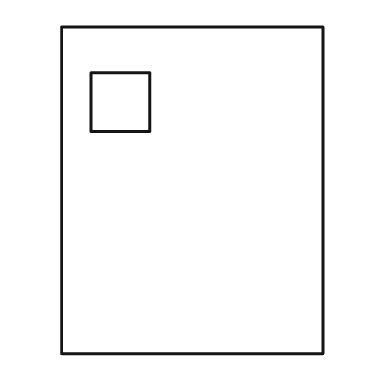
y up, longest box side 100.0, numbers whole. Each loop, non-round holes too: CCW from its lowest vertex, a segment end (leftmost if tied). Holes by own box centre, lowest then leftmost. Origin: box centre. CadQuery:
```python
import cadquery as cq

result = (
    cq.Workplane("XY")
    .moveTo(-40.0, -50.0)
    .lineTo(40.0, -50.0)
    .lineTo(40.0, 50.0)
    .lineTo(-40.0, 50.0)
    .close()
    .moveTo(-31.0, 18.0)
    .lineTo(-13.0, 18.0)
    .lineTo(-13.0, 36.0)
    .lineTo(-31.0, 36.0)
    .close()
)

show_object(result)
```